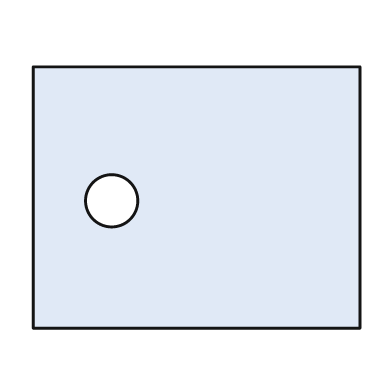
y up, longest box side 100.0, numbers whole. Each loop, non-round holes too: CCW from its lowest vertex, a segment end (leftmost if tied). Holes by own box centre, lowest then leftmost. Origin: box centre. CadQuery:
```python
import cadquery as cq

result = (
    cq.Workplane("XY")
    .moveTo(-50.0, -40.0)
    .lineTo(50.0, -40.0)
    .lineTo(50.0, 40.0)
    .lineTo(-50.0, 40.0)
    .close()
    .moveTo(-26.0, -1.0)
    .circle(8.0)
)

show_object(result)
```